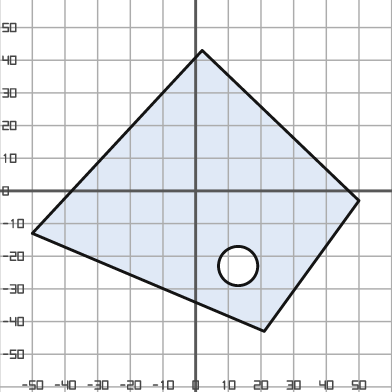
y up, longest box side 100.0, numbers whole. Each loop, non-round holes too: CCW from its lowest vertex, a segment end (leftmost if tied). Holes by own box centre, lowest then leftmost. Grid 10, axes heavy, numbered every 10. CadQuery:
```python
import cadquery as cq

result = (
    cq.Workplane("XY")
    .moveTo(21.0, -43.0)
    .lineTo(50.0, -3.0)
    .lineTo(2.0, 43.0)
    .lineTo(-50.0, -13.0)
    .close()
    .moveTo(13.0, -23.0)
    .circle(6.0)
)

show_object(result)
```